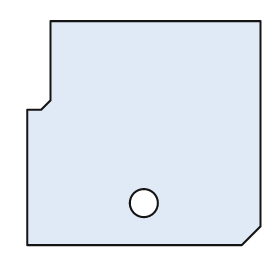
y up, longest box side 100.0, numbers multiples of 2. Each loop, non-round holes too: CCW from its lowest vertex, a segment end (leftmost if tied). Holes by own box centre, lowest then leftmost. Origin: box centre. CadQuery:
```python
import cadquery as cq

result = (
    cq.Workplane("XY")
    .moveTo(-50.0, -48.0)
    .lineTo(42.0, -48.0)
    .lineTo(50.0, -40.0)
    .lineTo(50.0, 48.0)
    .lineTo(-40.0, 48.0)
    .lineTo(-40.0, 14.0)
    .lineTo(-44.0, 10.0)
    .lineTo(-50.0, 10.0)
    .close()
    .moveTo(0.0, -30.0)
    .circle(6.0)
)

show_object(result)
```